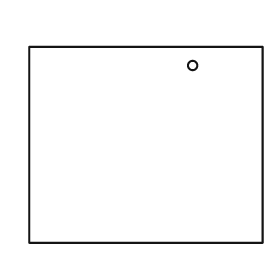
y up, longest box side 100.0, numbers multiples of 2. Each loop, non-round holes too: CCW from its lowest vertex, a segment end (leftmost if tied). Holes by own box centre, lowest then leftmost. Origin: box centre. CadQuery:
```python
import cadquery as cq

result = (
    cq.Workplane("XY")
    .moveTo(-50.0, -42.0)
    .lineTo(50.0, -42.0)
    .lineTo(50.0, 42.0)
    .lineTo(-50.0, 42.0)
    .close()
    .moveTo(20.0, 34.0)
    .circle(2.0)
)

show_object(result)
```